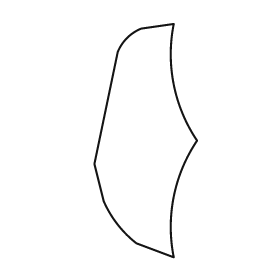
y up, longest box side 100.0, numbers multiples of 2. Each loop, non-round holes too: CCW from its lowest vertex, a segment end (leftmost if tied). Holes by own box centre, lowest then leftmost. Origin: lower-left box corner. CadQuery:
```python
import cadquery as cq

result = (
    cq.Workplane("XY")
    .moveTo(34.0, 0.0)
    .threePointArc((34.0, 26.0), (44.0, 50.0))
    .threePointArc((34.0, 74.0), (34.0, 100.0))
    .lineTo(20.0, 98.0)
    .threePointArc((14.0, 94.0), (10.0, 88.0))
    .lineTo(0.0, 40.0)
    .lineTo(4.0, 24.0)
    .threePointArc((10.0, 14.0), (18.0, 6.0))
    .close()
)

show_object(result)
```